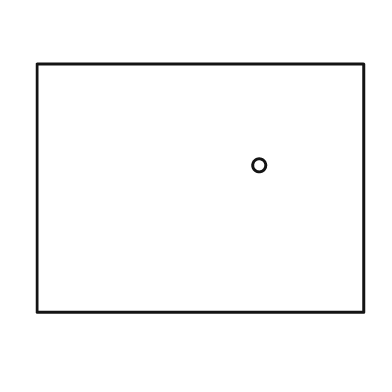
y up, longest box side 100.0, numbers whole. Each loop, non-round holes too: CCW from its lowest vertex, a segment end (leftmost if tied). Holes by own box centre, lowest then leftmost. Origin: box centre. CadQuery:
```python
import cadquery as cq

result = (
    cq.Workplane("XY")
    .moveTo(-50.0, -38.0)
    .lineTo(50.0, -38.0)
    .lineTo(50.0, 38.0)
    .lineTo(-50.0, 38.0)
    .close()
    .moveTo(18.0, 7.0)
    .circle(2.0)
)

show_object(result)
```